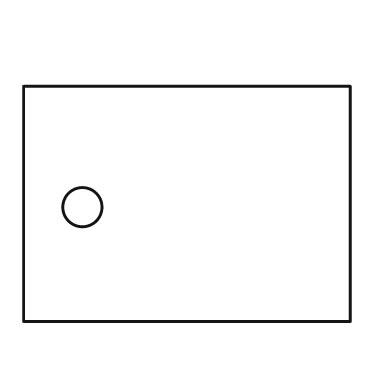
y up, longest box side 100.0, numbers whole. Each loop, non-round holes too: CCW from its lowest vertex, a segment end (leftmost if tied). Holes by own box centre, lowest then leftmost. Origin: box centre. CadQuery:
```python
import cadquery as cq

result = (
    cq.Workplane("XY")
    .moveTo(-50.0, -36.0)
    .lineTo(50.0, -36.0)
    .lineTo(50.0, 36.0)
    .lineTo(-50.0, 36.0)
    .close()
    .moveTo(-32.0, -1.0)
    .circle(6.0)
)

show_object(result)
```